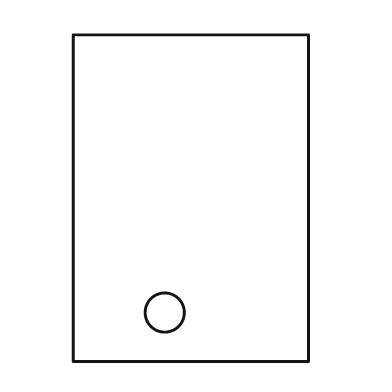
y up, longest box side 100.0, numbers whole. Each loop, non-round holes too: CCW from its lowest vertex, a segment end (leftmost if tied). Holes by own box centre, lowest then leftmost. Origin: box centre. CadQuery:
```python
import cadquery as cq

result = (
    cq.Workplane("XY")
    .moveTo(-36.0, -50.0)
    .lineTo(36.0, -50.0)
    .lineTo(36.0, 50.0)
    .lineTo(-36.0, 50.0)
    .close()
    .moveTo(-8.0, -35.0)
    .circle(6.0)
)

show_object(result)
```